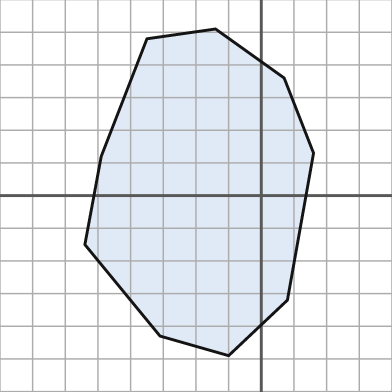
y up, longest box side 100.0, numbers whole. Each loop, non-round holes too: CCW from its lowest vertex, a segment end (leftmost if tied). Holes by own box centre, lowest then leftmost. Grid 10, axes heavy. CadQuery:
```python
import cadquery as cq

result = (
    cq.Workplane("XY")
    .moveTo(-10.0, -49.0)
    .lineTo(8.0, -32.0)
    .lineTo(16.0, 13.0)
    .lineTo(7.0, 36.0)
    .lineTo(-14.0, 51.0)
    .lineTo(-35.0, 48.0)
    .lineTo(-49.0, 12.0)
    .lineTo(-54.0, -15.0)
    .lineTo(-31.0, -43.0)
    .close()
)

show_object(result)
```